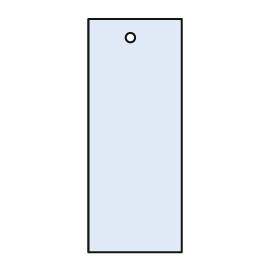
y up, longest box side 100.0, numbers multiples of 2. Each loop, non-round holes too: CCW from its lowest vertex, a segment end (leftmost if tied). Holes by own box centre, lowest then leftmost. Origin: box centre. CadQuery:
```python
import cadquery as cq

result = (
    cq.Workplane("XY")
    .moveTo(-20.0, -50.0)
    .lineTo(20.0, -50.0)
    .lineTo(20.0, 50.0)
    .lineTo(-20.0, 50.0)
    .close()
    .moveTo(-2.0, 42.0)
    .circle(2.0)
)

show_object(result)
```